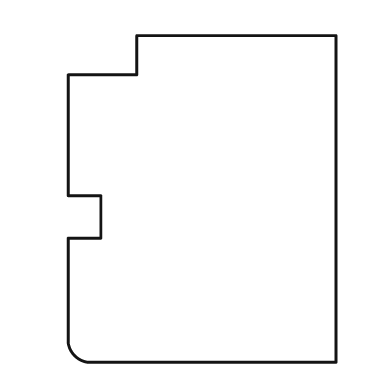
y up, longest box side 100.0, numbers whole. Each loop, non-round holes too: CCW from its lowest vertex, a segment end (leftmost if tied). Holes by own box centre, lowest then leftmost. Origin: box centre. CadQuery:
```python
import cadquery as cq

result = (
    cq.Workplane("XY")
    .moveTo(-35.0, -50.0)
    .lineTo(41.0, -50.0)
    .lineTo(41.0, 50.0)
    .lineTo(-20.0, 50.0)
    .lineTo(-20.0, 38.0)
    .lineTo(-41.0, 38.0)
    .lineTo(-41.0, 1.0)
    .lineTo(-31.0, 1.0)
    .lineTo(-31.0, -12.0)
    .lineTo(-41.0, -12.0)
    .lineTo(-41.0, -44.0)
    .threePointArc((-39.0, -48.0), (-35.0, -50.0))
    .close()
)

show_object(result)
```